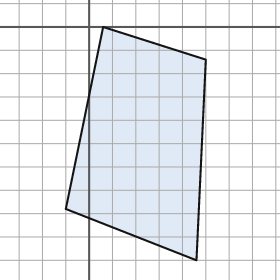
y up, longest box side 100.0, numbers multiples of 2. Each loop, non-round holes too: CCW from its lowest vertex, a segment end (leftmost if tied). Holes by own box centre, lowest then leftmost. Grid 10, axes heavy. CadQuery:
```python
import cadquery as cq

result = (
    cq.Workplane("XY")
    .moveTo(46.0, -100.0)
    .lineTo(50.0, -14.0)
    .lineTo(6.0, 0.0)
    .lineTo(-10.0, -78.0)
    .close()
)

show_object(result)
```